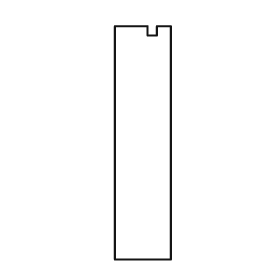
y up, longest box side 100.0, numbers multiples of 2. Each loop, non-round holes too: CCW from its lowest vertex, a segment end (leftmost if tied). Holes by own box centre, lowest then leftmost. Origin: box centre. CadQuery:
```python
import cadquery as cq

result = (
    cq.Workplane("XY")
    .moveTo(-12.0, -50.0)
    .lineTo(12.0, -50.0)
    .lineTo(12.0, 50.0)
    .lineTo(6.0, 50.0)
    .lineTo(6.0, 46.0)
    .lineTo(2.0, 46.0)
    .lineTo(2.0, 50.0)
    .lineTo(-12.0, 50.0)
    .close()
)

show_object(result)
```